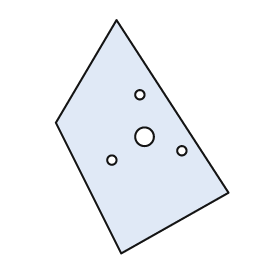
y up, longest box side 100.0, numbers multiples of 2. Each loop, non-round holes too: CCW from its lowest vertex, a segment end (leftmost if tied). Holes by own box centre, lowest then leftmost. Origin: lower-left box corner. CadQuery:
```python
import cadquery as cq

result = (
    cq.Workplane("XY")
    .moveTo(28.0, 0.0)
    .lineTo(74.0, 26.0)
    .lineTo(26.0, 100.0)
    .lineTo(0.0, 56.0)
    .close()
    .moveTo(24.0, 40.0)
    .circle(2.0)
    .moveTo(54.0, 44.0)
    .circle(2.0)
    .moveTo(38.0, 50.0)
    .circle(4.0)
    .moveTo(36.0, 68.0)
    .circle(2.0)
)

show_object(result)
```